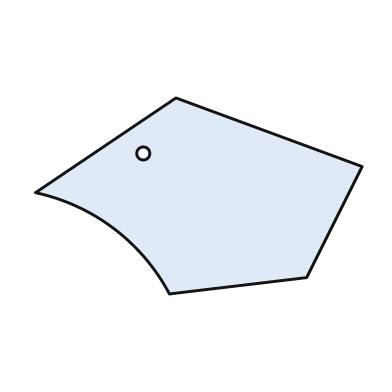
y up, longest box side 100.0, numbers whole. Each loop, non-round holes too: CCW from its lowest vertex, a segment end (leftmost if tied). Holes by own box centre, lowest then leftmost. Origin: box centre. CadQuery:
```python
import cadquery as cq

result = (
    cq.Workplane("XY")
    .moveTo(-9.0, -30.0)
    .lineTo(33.0, -25.0)
    .lineTo(50.0, 9.0)
    .lineTo(-7.0, 30.0)
    .lineTo(-50.0, 1.0)
    .threePointArc((-26.0, -10.0), (-9.0, -30.0))
    .close()
    .moveTo(-17.0, 13.0)
    .circle(2.0)
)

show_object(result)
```